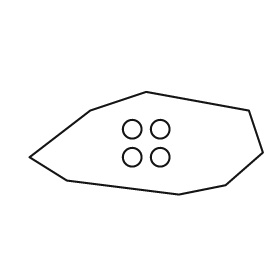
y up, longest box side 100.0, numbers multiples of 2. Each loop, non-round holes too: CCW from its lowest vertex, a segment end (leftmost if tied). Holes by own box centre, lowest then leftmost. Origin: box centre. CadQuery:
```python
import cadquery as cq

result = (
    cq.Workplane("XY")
    .moveTo(14.0, -22.0)
    .lineTo(34.0, -18.0)
    .lineTo(50.0, -4.0)
    .lineTo(44.0, 14.0)
    .lineTo(0.0, 22.0)
    .lineTo(-24.0, 14.0)
    .lineTo(-50.0, -6.0)
    .lineTo(-34.0, -16.0)
    .close()
    .moveTo(-6.0, -6.0)
    .circle(4.0)
    .moveTo(6.0, -6.0)
    .circle(4.0)
    .moveTo(-6.0, 6.0)
    .circle(4.0)
    .moveTo(6.0, 6.0)
    .circle(4.0)
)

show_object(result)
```